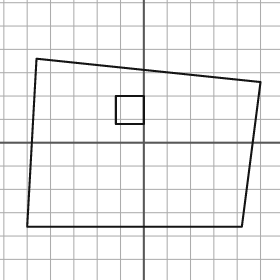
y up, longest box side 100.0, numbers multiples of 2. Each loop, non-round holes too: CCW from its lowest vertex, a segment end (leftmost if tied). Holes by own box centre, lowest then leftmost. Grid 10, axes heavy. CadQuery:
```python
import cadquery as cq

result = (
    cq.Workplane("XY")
    .moveTo(-50.0, -36.0)
    .lineTo(42.0, -36.0)
    .lineTo(50.0, 26.0)
    .lineTo(-46.0, 36.0)
    .close()
    .moveTo(-12.0, 8.0)
    .lineTo(0.0, 8.0)
    .lineTo(0.0, 20.0)
    .lineTo(-12.0, 20.0)
    .close()
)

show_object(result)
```